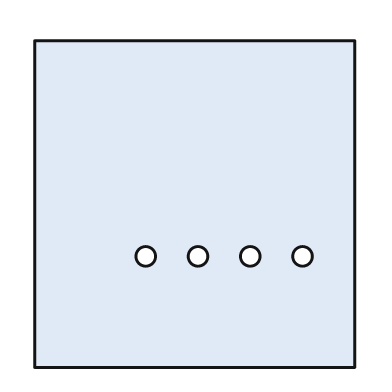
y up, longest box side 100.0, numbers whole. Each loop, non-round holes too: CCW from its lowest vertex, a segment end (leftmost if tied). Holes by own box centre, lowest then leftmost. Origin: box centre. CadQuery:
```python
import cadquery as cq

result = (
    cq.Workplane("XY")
    .moveTo(-49.0, -50.0)
    .lineTo(49.0, -50.0)
    .lineTo(49.0, 50.0)
    .lineTo(-49.0, 50.0)
    .close()
    .moveTo(-15.0, -16.0)
    .circle(3.0)
    .moveTo(1.0, -16.0)
    .circle(3.0)
    .moveTo(17.0, -16.0)
    .circle(3.0)
    .moveTo(33.0, -16.0)
    .circle(3.0)
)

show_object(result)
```